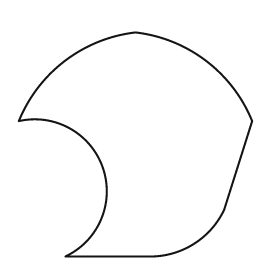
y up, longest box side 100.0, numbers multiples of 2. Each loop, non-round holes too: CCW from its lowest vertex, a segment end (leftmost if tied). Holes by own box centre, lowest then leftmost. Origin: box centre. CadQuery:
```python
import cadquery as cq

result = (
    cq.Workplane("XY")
    .moveTo(-30.0, -48.0)
    .lineTo(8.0, -48.0)
    .threePointArc((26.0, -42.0), (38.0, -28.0))
    .lineTo(50.0, 10.0)
    .threePointArc((30.0, 36.0), (0.0, 48.0))
    .threePointArc((-30.0, 36.0), (-50.0, 10.0))
    .threePointArc((-14.0, -10.0), (-30.0, -48.0))
    .close()
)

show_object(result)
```